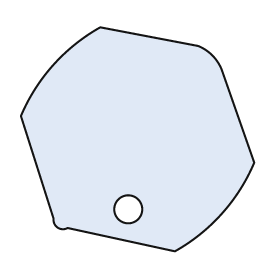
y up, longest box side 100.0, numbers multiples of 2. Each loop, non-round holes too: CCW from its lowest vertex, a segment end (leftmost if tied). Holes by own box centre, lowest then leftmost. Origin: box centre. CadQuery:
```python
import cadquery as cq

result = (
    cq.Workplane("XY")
    .moveTo(16.0, -48.0)
    .threePointArc((36.0, -32.0), (50.0, -10.0))
    .lineTo(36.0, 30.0)
    .threePointArc((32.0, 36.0), (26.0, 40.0))
    .lineTo(-16.0, 48.0)
    .threePointArc((-36.0, 32.0), (-50.0, 10.0))
    .lineTo(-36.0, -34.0)
    .threePointArc((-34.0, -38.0), (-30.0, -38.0))
    .close()
    .moveTo(-4.0, -30.0)
    .circle(6.0)
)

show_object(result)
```